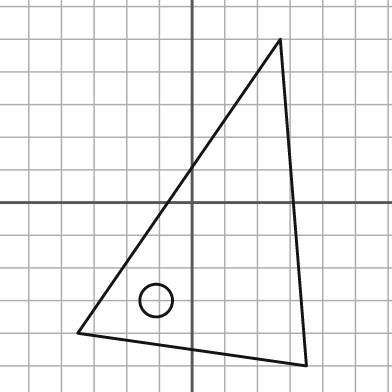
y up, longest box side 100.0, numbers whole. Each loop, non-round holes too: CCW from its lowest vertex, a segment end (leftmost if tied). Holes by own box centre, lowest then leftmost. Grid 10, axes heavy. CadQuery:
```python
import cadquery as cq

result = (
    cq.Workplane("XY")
    .moveTo(35.0, -50.0)
    .lineTo(27.0, 50.0)
    .lineTo(-35.0, -40.0)
    .close()
    .moveTo(-11.0, -30.0)
    .circle(5.0)
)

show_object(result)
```